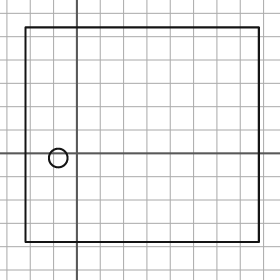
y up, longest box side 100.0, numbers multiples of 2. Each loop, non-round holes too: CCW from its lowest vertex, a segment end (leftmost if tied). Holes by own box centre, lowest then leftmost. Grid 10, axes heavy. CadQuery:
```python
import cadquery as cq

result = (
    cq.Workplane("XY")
    .moveTo(-22.0, -38.0)
    .lineTo(78.0, -38.0)
    .lineTo(78.0, 54.0)
    .lineTo(-22.0, 54.0)
    .close()
    .moveTo(-8.0, -2.0)
    .circle(4.0)
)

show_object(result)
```